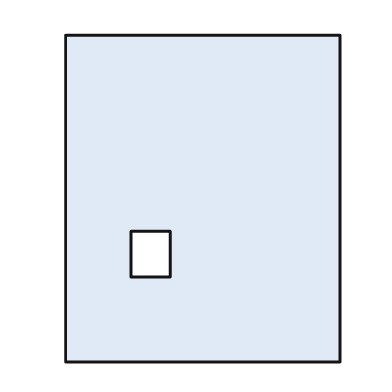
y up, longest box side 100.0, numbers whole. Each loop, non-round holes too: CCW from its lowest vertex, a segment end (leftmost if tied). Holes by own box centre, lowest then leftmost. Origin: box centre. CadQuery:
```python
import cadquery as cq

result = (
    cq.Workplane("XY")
    .moveTo(-42.0, -50.0)
    .lineTo(42.0, -50.0)
    .lineTo(42.0, 50.0)
    .lineTo(-42.0, 50.0)
    .close()
    .moveTo(-22.0, -24.0)
    .lineTo(-10.0, -24.0)
    .lineTo(-10.0, -10.0)
    .lineTo(-22.0, -10.0)
    .close()
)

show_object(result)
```